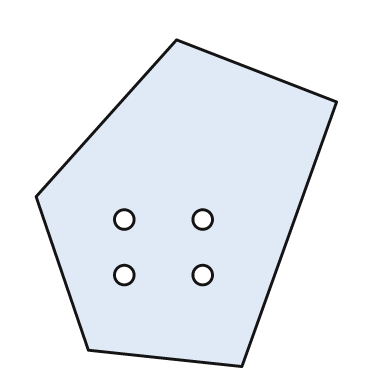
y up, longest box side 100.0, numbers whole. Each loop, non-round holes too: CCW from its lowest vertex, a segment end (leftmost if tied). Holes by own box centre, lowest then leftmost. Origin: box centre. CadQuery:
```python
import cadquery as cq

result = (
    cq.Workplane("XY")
    .moveTo(17.0, -50.0)
    .lineTo(46.0, 31.0)
    .lineTo(-3.0, 50.0)
    .lineTo(-46.0, 2.0)
    .lineTo(-30.0, -45.0)
    .close()
    .moveTo(-19.0, -22.0)
    .circle(3.0)
    .moveTo(5.0, -22.0)
    .circle(3.0)
    .moveTo(-19.0, -5.0)
    .circle(3.0)
    .moveTo(5.0, -5.0)
    .circle(3.0)
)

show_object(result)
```